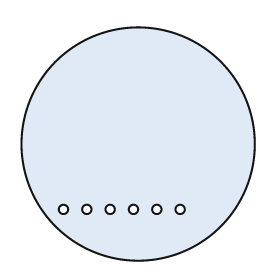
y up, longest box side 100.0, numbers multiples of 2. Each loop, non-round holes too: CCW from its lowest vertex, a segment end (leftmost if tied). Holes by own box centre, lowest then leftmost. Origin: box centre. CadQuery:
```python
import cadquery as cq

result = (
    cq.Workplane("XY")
    .moveTo(0.0, 0.0)
    .circle(50.0)
    .moveTo(-32.0, -28.0)
    .circle(2.0)
    .moveTo(-22.0, -28.0)
    .circle(2.0)
    .moveTo(-12.0, -28.0)
    .circle(2.0)
    .moveTo(-2.0, -28.0)
    .circle(2.0)
    .moveTo(8.0, -28.0)
    .circle(2.0)
    .moveTo(18.0, -28.0)
    .circle(2.0)
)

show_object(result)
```